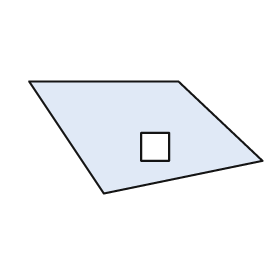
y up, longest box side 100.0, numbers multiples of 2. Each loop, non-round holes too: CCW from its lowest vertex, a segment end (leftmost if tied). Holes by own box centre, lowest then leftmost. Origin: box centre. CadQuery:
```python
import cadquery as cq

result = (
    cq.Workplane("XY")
    .moveTo(-18.0, -24.0)
    .lineTo(50.0, -10.0)
    .lineTo(14.0, 24.0)
    .lineTo(-50.0, 24.0)
    .close()
    .moveTo(-2.0, -10.0)
    .lineTo(10.0, -10.0)
    .lineTo(10.0, 2.0)
    .lineTo(-2.0, 2.0)
    .close()
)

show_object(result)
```